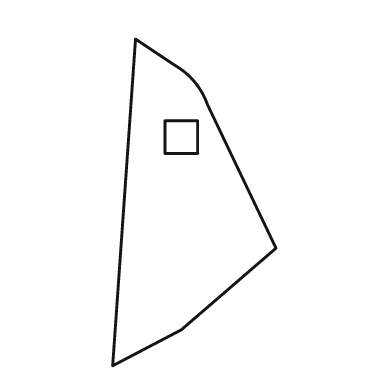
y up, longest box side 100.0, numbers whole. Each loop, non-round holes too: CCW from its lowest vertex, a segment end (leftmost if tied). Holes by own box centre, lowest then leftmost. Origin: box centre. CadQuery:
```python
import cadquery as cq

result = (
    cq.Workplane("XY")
    .moveTo(-25.0, -50.0)
    .lineTo(-4.0, -39.0)
    .lineTo(25.0, -14.0)
    .lineTo(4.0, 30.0)
    .threePointArc((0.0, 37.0), (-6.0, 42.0))
    .lineTo(-18.0, 50.0)
    .close()
    .moveTo(-9.0, 15.0)
    .lineTo(1.0, 15.0)
    .lineTo(1.0, 25.0)
    .lineTo(-9.0, 25.0)
    .close()
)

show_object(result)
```